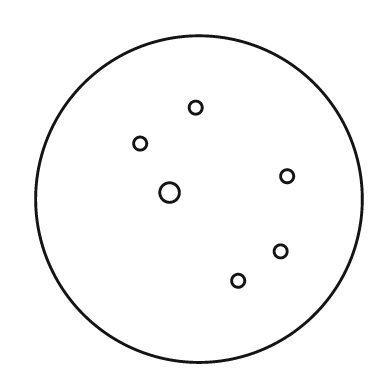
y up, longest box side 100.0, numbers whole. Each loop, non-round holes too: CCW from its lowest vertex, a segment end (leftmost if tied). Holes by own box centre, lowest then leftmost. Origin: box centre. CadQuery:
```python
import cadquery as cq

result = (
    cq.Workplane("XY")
    .moveTo(0.0, 0.0)
    .circle(50.0)
    .moveTo(12.0, -25.0)
    .circle(2.0)
    .moveTo(25.0, -16.0)
    .circle(2.0)
    .moveTo(-9.0, 2.0)
    .circle(3.0)
    .moveTo(27.0, 7.0)
    .circle(2.0)
    .moveTo(-18.0, 17.0)
    .circle(2.0)
    .moveTo(-1.0, 28.0)
    .circle(2.0)
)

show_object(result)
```